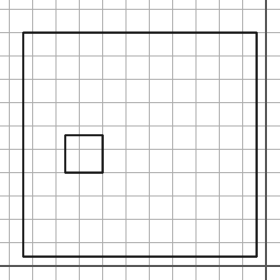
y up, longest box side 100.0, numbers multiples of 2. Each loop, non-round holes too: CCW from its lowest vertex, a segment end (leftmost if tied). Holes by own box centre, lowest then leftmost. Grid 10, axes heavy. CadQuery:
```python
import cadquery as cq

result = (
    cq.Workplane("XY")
    .moveTo(-104.0, 4.0)
    .lineTo(-4.0, 4.0)
    .lineTo(-4.0, 100.0)
    .lineTo(-104.0, 100.0)
    .close()
    .moveTo(-86.0, 40.0)
    .lineTo(-70.0, 40.0)
    .lineTo(-70.0, 56.0)
    .lineTo(-86.0, 56.0)
    .close()
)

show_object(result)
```